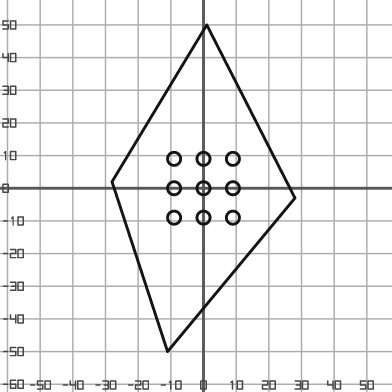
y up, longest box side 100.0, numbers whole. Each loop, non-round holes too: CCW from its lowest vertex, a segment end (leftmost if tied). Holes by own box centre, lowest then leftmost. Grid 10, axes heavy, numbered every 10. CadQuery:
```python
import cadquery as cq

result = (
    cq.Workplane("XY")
    .moveTo(-11.0, -50.0)
    .lineTo(28.0, -3.0)
    .lineTo(1.0, 50.0)
    .lineTo(-28.0, 2.0)
    .close()
    .moveTo(-9.0, -9.0)
    .circle(2.0)
    .moveTo(0.0, -9.0)
    .circle(2.0)
    .moveTo(9.0, -9.0)
    .circle(2.0)
    .moveTo(-9.0, 0.0)
    .circle(2.0)
    .moveTo(0.0, 0.0)
    .circle(2.0)
    .moveTo(9.0, 0.0)
    .circle(2.0)
    .moveTo(-9.0, 9.0)
    .circle(2.0)
    .moveTo(0.0, 9.0)
    .circle(2.0)
    .moveTo(9.0, 9.0)
    .circle(2.0)
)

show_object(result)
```